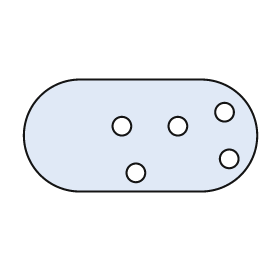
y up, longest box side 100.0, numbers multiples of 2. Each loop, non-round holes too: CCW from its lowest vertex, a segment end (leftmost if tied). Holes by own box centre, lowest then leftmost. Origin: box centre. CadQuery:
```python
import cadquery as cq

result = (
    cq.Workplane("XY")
    .moveTo(-26.0, -24.0)
    .lineTo(26.0, -24.0)
    .threePointArc((50.0, 0.0), (26.0, 24.0))
    .lineTo(-26.0, 24.0)
    .threePointArc((-50.0, 0.0), (-26.0, -24.0))
    .close()
    .moveTo(-2.0, -16.0)
    .circle(4.0)
    .moveTo(38.0, -10.0)
    .circle(4.0)
    .moveTo(-8.0, 4.0)
    .circle(4.0)
    .moveTo(16.0, 4.0)
    .circle(4.0)
    .moveTo(36.0, 10.0)
    .circle(4.0)
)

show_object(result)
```